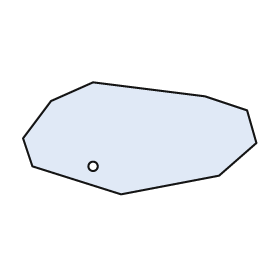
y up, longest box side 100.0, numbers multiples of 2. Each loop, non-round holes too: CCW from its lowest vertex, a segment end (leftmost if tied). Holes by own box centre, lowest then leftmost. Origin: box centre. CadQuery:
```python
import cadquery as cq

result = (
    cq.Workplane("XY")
    .moveTo(-8.0, -24.0)
    .lineTo(34.0, -16.0)
    .lineTo(50.0, -2.0)
    .lineTo(46.0, 12.0)
    .lineTo(28.0, 18.0)
    .lineTo(-20.0, 24.0)
    .lineTo(-38.0, 16.0)
    .lineTo(-50.0, 0.0)
    .lineTo(-46.0, -12.0)
    .close()
    .moveTo(-20.0, -12.0)
    .circle(2.0)
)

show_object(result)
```